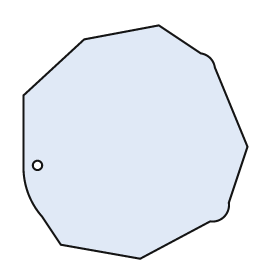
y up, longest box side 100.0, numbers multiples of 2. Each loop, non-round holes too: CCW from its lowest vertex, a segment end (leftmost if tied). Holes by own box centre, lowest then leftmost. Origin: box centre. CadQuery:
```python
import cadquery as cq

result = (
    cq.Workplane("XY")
    .moveTo(2.0, -50.0)
    .lineTo(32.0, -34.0)
    .threePointArc((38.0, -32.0), (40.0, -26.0))
    .lineTo(48.0, -2.0)
    .lineTo(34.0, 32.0)
    .threePointArc((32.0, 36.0), (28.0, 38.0))
    .lineTo(10.0, 50.0)
    .lineTo(-22.0, 44.0)
    .lineTo(-48.0, 20.0)
    .lineTo(-48.0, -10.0)
    .threePointArc((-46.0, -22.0), (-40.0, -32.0))
    .lineTo(-32.0, -44.0)
    .close()
    .moveTo(-42.0, -10.0)
    .circle(2.0)
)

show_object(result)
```